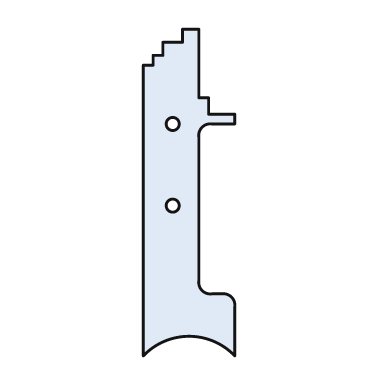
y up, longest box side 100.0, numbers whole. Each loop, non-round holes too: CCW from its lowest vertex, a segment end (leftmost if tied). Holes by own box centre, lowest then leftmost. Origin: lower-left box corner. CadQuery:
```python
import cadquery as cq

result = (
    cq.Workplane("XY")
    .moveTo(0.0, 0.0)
    .threePointArc((14.0, 6.0), (28.0, 0.0))
    .lineTo(28.0, 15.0)
    .threePointArc((27.0, 18.0), (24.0, 19.0))
    .lineTo(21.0, 19.0)
    .threePointArc((18.0, 20.0), (17.0, 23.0))
    .lineTo(17.0, 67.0)
    .threePointArc((18.0, 70.0), (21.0, 71.0))
    .lineTo(28.0, 71.0)
    .lineTo(28.0, 74.0)
    .lineTo(20.0, 74.0)
    .lineTo(20.0, 79.0)
    .lineTo(17.0, 79.0)
    .lineTo(17.0, 100.0)
    .lineTo(12.0, 100.0)
    .lineTo(12.0, 96.0)
    .lineTo(6.0, 96.0)
    .lineTo(6.0, 92.0)
    .lineTo(3.0, 92.0)
    .lineTo(3.0, 89.0)
    .lineTo(0.0, 89.0)
    .close()
    .moveTo(9.0, 46.0)
    .circle(2.0)
    .moveTo(9.0, 71.0)
    .circle(2.0)
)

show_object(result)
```